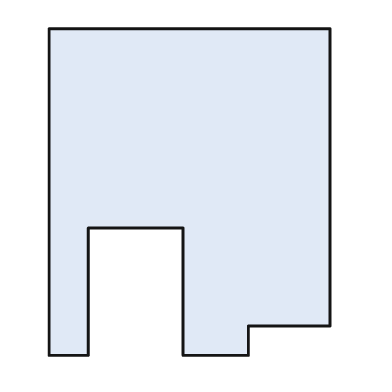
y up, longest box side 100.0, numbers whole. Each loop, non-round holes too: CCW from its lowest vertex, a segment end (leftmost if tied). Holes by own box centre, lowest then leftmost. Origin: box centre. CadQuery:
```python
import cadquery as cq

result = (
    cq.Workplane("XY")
    .moveTo(-43.0, -50.0)
    .lineTo(-31.0, -50.0)
    .lineTo(-31.0, -11.0)
    .lineTo(-2.0, -11.0)
    .lineTo(-2.0, -50.0)
    .lineTo(18.0, -50.0)
    .lineTo(18.0, -41.0)
    .lineTo(43.0, -41.0)
    .lineTo(43.0, 50.0)
    .lineTo(-43.0, 50.0)
    .close()
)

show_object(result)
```